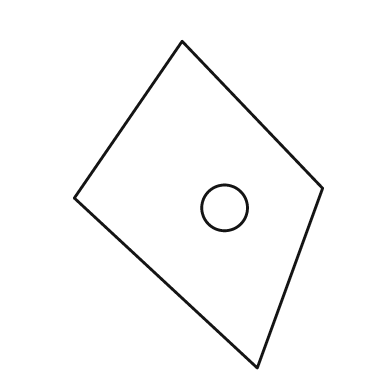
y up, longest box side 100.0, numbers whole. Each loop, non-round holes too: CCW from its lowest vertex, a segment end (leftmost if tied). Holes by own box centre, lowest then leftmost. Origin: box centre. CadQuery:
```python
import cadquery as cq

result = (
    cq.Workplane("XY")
    .moveTo(18.0, -50.0)
    .lineTo(38.0, 5.0)
    .lineTo(-5.0, 50.0)
    .lineTo(-38.0, 2.0)
    .close()
    .moveTo(8.0, -1.0)
    .circle(7.0)
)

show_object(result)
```